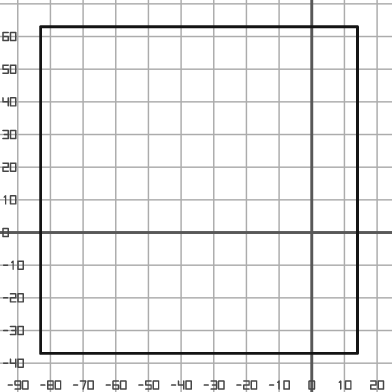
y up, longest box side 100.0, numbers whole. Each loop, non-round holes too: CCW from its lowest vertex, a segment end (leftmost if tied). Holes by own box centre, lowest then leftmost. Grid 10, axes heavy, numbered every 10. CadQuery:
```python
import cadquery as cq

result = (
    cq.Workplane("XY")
    .moveTo(-83.0, -37.0)
    .lineTo(14.0, -37.0)
    .lineTo(14.0, 63.0)
    .lineTo(-83.0, 63.0)
    .close()
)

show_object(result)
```